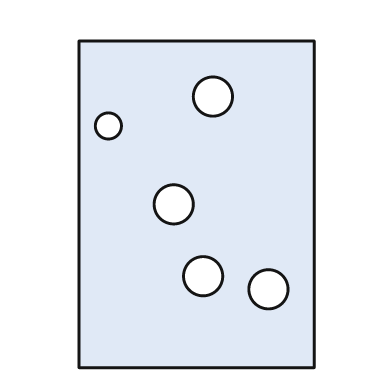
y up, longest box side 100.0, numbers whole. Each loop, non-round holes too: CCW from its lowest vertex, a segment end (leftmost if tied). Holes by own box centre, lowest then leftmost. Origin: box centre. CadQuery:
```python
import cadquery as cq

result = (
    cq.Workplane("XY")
    .moveTo(-36.0, -50.0)
    .lineTo(36.0, -50.0)
    .lineTo(36.0, 50.0)
    .lineTo(-36.0, 50.0)
    .close()
    .moveTo(22.0, -26.0)
    .circle(6.0)
    .moveTo(2.0, -22.0)
    .circle(6.0)
    .moveTo(-7.0, 0.0)
    .circle(6.0)
    .moveTo(-27.0, 24.0)
    .circle(4.0)
    .moveTo(5.0, 33.0)
    .circle(6.0)
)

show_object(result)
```